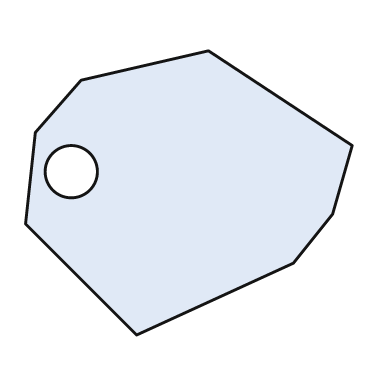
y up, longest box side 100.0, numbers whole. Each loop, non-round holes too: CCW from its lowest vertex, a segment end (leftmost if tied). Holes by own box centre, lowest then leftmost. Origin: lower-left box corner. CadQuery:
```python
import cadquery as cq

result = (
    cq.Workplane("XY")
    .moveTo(34.0, 0.0)
    .lineTo(82.0, 22.0)
    .lineTo(94.0, 37.0)
    .lineTo(100.0, 58.0)
    .lineTo(56.0, 87.0)
    .lineTo(17.0, 78.0)
    .lineTo(3.0, 62.0)
    .lineTo(0.0, 34.0)
    .close()
    .moveTo(14.0, 50.0)
    .circle(8.0)
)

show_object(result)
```